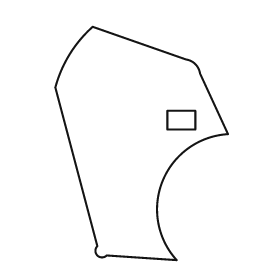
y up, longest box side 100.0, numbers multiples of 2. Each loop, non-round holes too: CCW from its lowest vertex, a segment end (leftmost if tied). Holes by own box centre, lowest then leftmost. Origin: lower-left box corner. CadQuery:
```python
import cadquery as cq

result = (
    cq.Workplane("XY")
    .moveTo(52.0, 0.0)
    .threePointArc((46.0, 34.0), (74.0, 54.0))
    .lineTo(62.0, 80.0)
    .threePointArc((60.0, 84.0), (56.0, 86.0))
    .lineTo(16.0, 100.0)
    .threePointArc((6.0, 88.0), (0.0, 74.0))
    .lineTo(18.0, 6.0)
    .threePointArc((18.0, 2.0), (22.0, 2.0))
    .close()
    .moveTo(48.0, 56.0)
    .lineTo(60.0, 56.0)
    .lineTo(60.0, 64.0)
    .lineTo(48.0, 64.0)
    .close()
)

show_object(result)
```